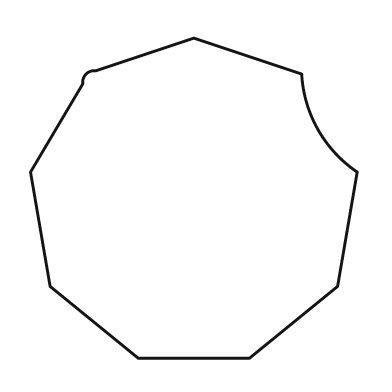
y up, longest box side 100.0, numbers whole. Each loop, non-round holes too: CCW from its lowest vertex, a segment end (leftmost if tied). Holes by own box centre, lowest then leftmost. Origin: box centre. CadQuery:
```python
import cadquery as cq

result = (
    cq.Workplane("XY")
    .moveTo(-17.0, -49.0)
    .lineTo(17.0, -49.0)
    .lineTo(44.0, -27.0)
    .lineTo(50.0, 8.0)
    .threePointArc((38.0, 21.0), (33.0, 38.0))
    .lineTo(0.0, 49.0)
    .lineTo(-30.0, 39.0)
    .threePointArc((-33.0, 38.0), (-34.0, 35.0))
    .lineTo(-50.0, 8.0)
    .lineTo(-44.0, -27.0)
    .close()
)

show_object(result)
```